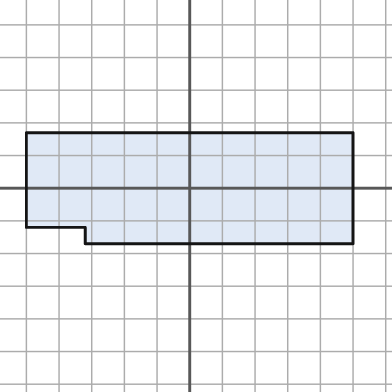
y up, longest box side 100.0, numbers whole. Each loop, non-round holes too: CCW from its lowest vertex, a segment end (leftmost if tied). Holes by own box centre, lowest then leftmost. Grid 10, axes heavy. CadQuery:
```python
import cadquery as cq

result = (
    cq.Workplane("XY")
    .moveTo(-32.0, -17.0)
    .lineTo(50.0, -17.0)
    .lineTo(50.0, 17.0)
    .lineTo(-50.0, 17.0)
    .lineTo(-50.0, -12.0)
    .lineTo(-32.0, -12.0)
    .close()
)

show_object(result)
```